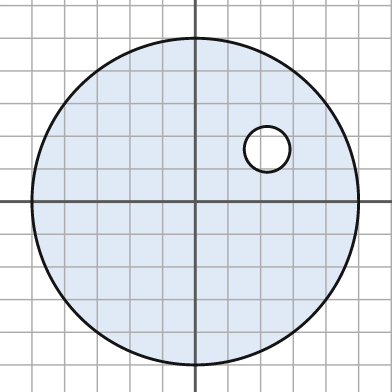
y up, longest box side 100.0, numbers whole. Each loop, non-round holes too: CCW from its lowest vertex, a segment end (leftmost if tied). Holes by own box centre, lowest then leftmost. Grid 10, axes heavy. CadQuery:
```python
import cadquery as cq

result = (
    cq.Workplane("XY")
    .moveTo(0.0, 0.0)
    .circle(50.0)
    .moveTo(22.0, 16.0)
    .circle(7.0)
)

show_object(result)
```